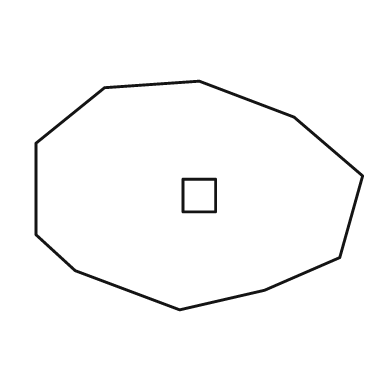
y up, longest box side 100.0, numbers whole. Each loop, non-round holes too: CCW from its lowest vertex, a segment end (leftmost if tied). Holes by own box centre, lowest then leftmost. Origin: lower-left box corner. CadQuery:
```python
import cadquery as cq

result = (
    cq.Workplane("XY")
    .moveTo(44.0, 0.0)
    .lineTo(70.0, 6.0)
    .lineTo(93.0, 16.0)
    .lineTo(100.0, 41.0)
    .lineTo(79.0, 59.0)
    .lineTo(50.0, 70.0)
    .lineTo(21.0, 68.0)
    .lineTo(0.0, 51.0)
    .lineTo(0.0, 23.0)
    .lineTo(12.0, 12.0)
    .close()
    .moveTo(45.0, 30.0)
    .lineTo(55.0, 30.0)
    .lineTo(55.0, 40.0)
    .lineTo(45.0, 40.0)
    .close()
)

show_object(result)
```